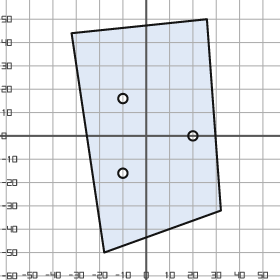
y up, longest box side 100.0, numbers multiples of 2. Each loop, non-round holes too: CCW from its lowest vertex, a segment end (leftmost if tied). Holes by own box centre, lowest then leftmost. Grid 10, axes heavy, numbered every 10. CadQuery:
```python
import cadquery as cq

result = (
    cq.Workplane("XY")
    .moveTo(-18.0, -50.0)
    .lineTo(32.0, -32.0)
    .lineTo(26.0, 50.0)
    .lineTo(-32.0, 44.0)
    .close()
    .moveTo(-10.0, -16.0)
    .circle(2.0)
    .moveTo(20.0, 0.0)
    .circle(2.0)
    .moveTo(-10.0, 16.0)
    .circle(2.0)
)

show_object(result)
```